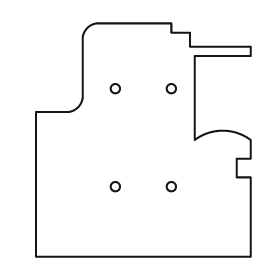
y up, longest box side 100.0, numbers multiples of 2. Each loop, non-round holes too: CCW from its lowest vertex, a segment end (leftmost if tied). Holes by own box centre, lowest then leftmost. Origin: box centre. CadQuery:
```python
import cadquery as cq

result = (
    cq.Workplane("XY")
    .moveTo(-46.0, -50.0)
    .lineTo(46.0, -50.0)
    .lineTo(46.0, -16.0)
    .lineTo(40.0, -16.0)
    .lineTo(40.0, -8.0)
    .lineTo(46.0, -8.0)
    .lineTo(46.0, 0.0)
    .threePointArc((34.0, 4.0), (22.0, 0.0))
    .lineTo(22.0, 36.0)
    .lineTo(46.0, 36.0)
    .lineTo(46.0, 40.0)
    .lineTo(20.0, 40.0)
    .lineTo(20.0, 46.0)
    .lineTo(12.0, 46.0)
    .lineTo(12.0, 50.0)
    .lineTo(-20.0, 50.0)
    .threePointArc((-24.0, 48.0), (-26.0, 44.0))
    .lineTo(-26.0, 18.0)
    .threePointArc((-28.0, 14.0), (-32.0, 12.0))
    .lineTo(-46.0, 12.0)
    .close()
    .moveTo(-12.0, -20.0)
    .circle(2.0)
    .moveTo(12.0, -20.0)
    .circle(2.0)
    .moveTo(-12.0, 22.0)
    .circle(2.0)
    .moveTo(12.0, 22.0)
    .circle(2.0)
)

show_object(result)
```